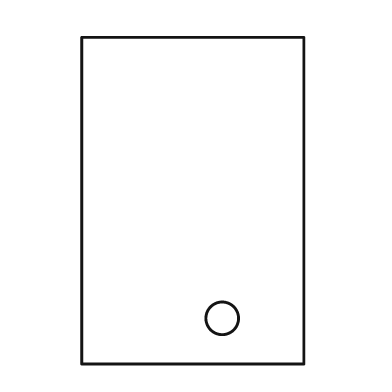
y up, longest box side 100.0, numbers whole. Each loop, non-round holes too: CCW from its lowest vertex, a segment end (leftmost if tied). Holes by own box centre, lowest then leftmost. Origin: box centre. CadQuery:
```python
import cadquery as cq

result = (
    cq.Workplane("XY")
    .moveTo(-34.0, -50.0)
    .lineTo(34.0, -50.0)
    .lineTo(34.0, 50.0)
    .lineTo(-34.0, 50.0)
    .close()
    .moveTo(9.0, -36.0)
    .circle(5.0)
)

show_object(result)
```